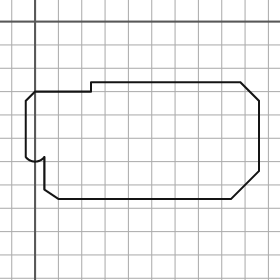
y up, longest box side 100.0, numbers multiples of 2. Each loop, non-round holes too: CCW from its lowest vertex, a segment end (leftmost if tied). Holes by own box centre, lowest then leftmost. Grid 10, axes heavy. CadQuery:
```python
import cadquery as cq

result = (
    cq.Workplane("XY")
    .moveTo(10.0, -76.0)
    .lineTo(84.0, -76.0)
    .lineTo(96.0, -64.0)
    .lineTo(96.0, -34.0)
    .lineTo(88.0, -26.0)
    .lineTo(24.0, -26.0)
    .lineTo(24.0, -30.0)
    .lineTo(0.0, -30.0)
    .lineTo(-4.0, -34.0)
    .lineTo(-4.0, -58.0)
    .threePointArc((0.0, -60.0), (4.0, -58.0))
    .lineTo(4.0, -72.0)
    .close()
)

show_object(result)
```